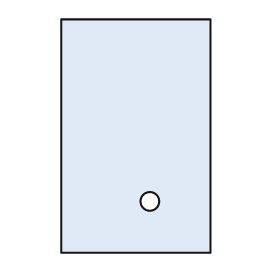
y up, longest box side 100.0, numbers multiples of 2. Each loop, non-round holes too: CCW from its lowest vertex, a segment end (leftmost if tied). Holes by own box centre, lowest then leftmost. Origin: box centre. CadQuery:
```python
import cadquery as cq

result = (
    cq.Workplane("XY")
    .moveTo(-32.0, -50.0)
    .lineTo(32.0, -50.0)
    .lineTo(32.0, 50.0)
    .lineTo(-32.0, 50.0)
    .close()
    .moveTo(6.0, -28.0)
    .circle(4.0)
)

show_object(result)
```